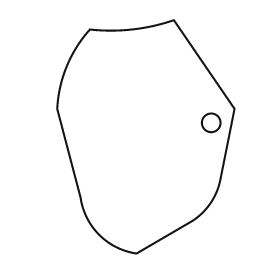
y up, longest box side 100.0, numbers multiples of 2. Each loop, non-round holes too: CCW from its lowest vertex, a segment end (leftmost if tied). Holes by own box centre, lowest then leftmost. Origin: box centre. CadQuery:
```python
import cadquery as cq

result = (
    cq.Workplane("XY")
    .moveTo(-4.0, -50.0)
    .lineTo(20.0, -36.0)
    .threePointArc((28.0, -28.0), (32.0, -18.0))
    .lineTo(38.0, 12.0)
    .lineTo(12.0, 50.0)
    .threePointArc((-6.0, 46.0), (-24.0, 46.0))
    .threePointArc((-34.0, 30.0), (-38.0, 12.0))
    .lineTo(-28.0, -26.0)
    .threePointArc((-20.0, -42.0), (-4.0, -50.0))
    .close()
    .moveTo(28.0, 6.0)
    .circle(4.0)
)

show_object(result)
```